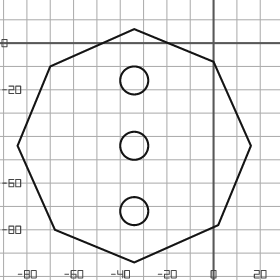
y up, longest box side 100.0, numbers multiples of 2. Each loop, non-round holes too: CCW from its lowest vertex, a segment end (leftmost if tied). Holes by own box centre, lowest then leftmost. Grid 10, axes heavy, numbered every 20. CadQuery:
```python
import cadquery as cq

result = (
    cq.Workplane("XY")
    .moveTo(-34.0, -94.0)
    .lineTo(2.0, -78.0)
    .lineTo(16.0, -44.0)
    .lineTo(0.0, -8.0)
    .lineTo(-34.0, 6.0)
    .lineTo(-70.0, -10.0)
    .lineTo(-84.0, -44.0)
    .lineTo(-68.0, -80.0)
    .close()
    .moveTo(-34.0, -72.0)
    .circle(6.0)
    .moveTo(-34.0, -44.0)
    .circle(6.0)
    .moveTo(-34.0, -16.0)
    .circle(6.0)
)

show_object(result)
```